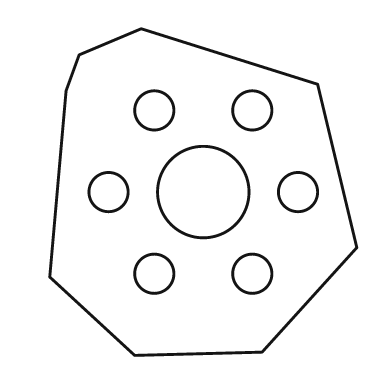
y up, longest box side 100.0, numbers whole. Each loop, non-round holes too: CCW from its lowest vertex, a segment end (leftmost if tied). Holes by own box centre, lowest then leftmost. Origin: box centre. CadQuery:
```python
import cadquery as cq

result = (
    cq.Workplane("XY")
    .moveTo(-21.0, -50.0)
    .lineTo(18.0, -49.0)
    .lineTo(47.0, -17.0)
    .lineTo(35.0, 33.0)
    .lineTo(-19.0, 50.0)
    .lineTo(-38.0, 42.0)
    .lineTo(-42.0, 31.0)
    .lineTo(-47.0, -26.0)
    .close()
    .moveTo(-15.0, -25.0)
    .circle(6.0)
    .moveTo(15.0, -25.0)
    .circle(6.0)
    .moveTo(-29.0, 0.0)
    .circle(6.0)
    .moveTo(0.0, 0.0)
    .circle(14.0)
    .moveTo(29.0, 0.0)
    .circle(6.0)
    .moveTo(-15.0, 25.0)
    .circle(6.0)
    .moveTo(15.0, 25.0)
    .circle(6.0)
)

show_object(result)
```